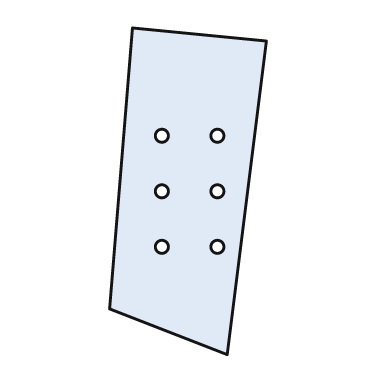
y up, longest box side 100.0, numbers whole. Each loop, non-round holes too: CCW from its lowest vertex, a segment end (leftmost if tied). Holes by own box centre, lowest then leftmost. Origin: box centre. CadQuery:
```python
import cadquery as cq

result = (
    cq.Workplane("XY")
    .moveTo(12.0, -50.0)
    .lineTo(24.0, 46.0)
    .lineTo(-17.0, 50.0)
    .lineTo(-24.0, -36.0)
    .close()
    .moveTo(-8.0, -17.0)
    .circle(2.0)
    .moveTo(9.0, -17.0)
    .circle(2.0)
    .moveTo(-8.0, 0.0)
    .circle(2.0)
    .moveTo(9.0, 0.0)
    .circle(2.0)
    .moveTo(-8.0, 17.0)
    .circle(2.0)
    .moveTo(9.0, 17.0)
    .circle(2.0)
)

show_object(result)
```